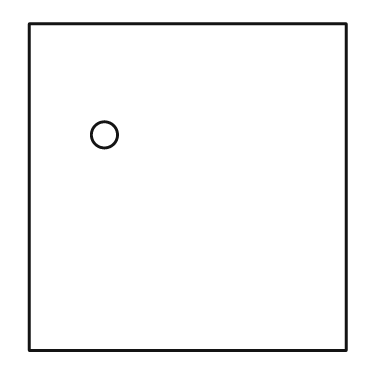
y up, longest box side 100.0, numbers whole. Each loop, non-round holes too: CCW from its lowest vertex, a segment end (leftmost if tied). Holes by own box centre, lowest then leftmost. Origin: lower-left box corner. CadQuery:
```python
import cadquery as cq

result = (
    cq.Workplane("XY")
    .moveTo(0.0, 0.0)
    .lineTo(97.0, 0.0)
    .lineTo(97.0, 100.0)
    .lineTo(0.0, 100.0)
    .close()
    .moveTo(23.0, 66.0)
    .circle(4.0)
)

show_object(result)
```